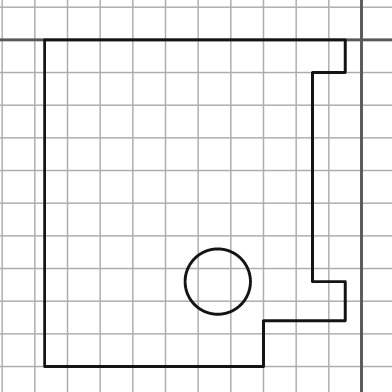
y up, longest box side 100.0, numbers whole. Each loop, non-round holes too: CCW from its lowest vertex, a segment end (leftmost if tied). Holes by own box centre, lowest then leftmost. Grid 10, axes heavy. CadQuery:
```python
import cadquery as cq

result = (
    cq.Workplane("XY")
    .moveTo(-97.0, -100.0)
    .lineTo(-30.0, -100.0)
    .lineTo(-30.0, -86.0)
    .lineTo(-5.0, -86.0)
    .lineTo(-5.0, -74.0)
    .lineTo(-15.0, -74.0)
    .lineTo(-15.0, -10.0)
    .lineTo(-5.0, -10.0)
    .lineTo(-5.0, 0.0)
    .lineTo(-97.0, 0.0)
    .close()
    .moveTo(-44.0, -74.0)
    .circle(10.0)
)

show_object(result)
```